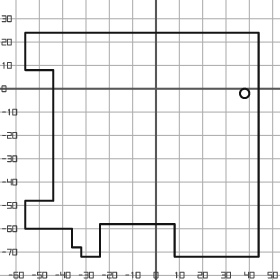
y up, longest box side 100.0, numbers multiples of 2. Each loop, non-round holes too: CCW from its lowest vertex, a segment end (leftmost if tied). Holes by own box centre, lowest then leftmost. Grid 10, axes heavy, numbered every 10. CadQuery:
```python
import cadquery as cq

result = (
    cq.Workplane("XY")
    .moveTo(-32.0, -72.0)
    .lineTo(-24.0, -72.0)
    .lineTo(-24.0, -58.0)
    .lineTo(8.0, -58.0)
    .lineTo(8.0, -72.0)
    .lineTo(44.0, -72.0)
    .lineTo(44.0, 24.0)
    .lineTo(-56.0, 24.0)
    .lineTo(-56.0, 8.0)
    .lineTo(-44.0, 8.0)
    .lineTo(-44.0, -48.0)
    .lineTo(-56.0, -48.0)
    .lineTo(-56.0, -60.0)
    .lineTo(-36.0, -60.0)
    .lineTo(-36.0, -68.0)
    .lineTo(-32.0, -68.0)
    .close()
    .moveTo(38.0, -2.0)
    .circle(2.0)
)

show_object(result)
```